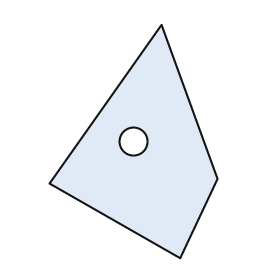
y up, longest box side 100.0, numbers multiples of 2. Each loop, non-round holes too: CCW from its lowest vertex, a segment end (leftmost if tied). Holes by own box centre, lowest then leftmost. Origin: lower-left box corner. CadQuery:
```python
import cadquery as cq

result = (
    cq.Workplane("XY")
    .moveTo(56.0, 0.0)
    .lineTo(72.0, 34.0)
    .lineTo(48.0, 100.0)
    .lineTo(0.0, 32.0)
    .close()
    .moveTo(36.0, 50.0)
    .circle(6.0)
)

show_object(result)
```